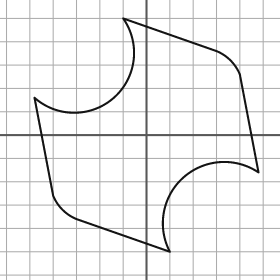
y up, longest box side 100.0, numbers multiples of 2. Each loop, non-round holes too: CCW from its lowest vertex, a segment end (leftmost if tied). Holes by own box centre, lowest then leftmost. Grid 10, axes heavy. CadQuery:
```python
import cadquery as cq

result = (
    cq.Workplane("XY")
    .moveTo(10.0, -50.0)
    .threePointArc((16.0, -18.0), (48.0, -16.0))
    .lineTo(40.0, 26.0)
    .threePointArc((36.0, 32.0), (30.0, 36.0))
    .lineTo(-10.0, 50.0)
    .threePointArc((-14.0, 16.0), (-48.0, 16.0))
    .lineTo(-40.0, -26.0)
    .threePointArc((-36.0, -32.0), (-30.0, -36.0))
    .close()
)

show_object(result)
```